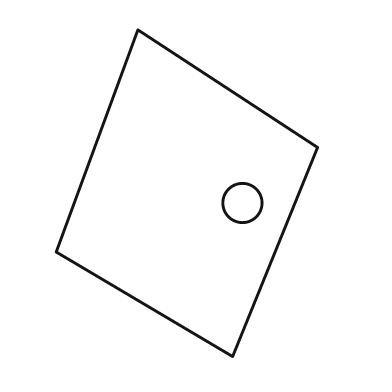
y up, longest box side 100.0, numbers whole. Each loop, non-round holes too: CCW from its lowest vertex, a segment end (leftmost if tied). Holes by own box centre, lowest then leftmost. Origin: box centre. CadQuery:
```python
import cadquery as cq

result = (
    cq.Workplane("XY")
    .moveTo(14.0, -50.0)
    .lineTo(40.0, 14.0)
    .lineTo(-15.0, 50.0)
    .lineTo(-40.0, -18.0)
    .close()
    .moveTo(17.0, -3.0)
    .circle(6.0)
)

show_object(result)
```